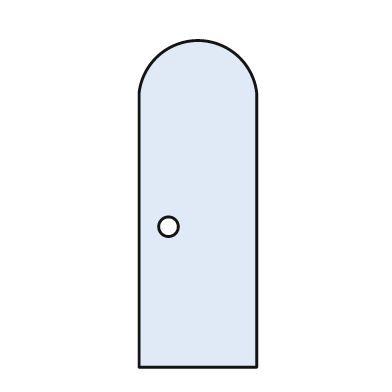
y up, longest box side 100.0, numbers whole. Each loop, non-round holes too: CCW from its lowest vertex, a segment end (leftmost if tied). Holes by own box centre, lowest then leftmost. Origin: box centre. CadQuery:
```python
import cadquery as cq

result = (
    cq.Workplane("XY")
    .moveTo(-18.0, -50.0)
    .lineTo(18.0, -50.0)
    .lineTo(18.0, 34.0)
    .threePointArc((0.0, 50.0), (-18.0, 34.0))
    .close()
    .moveTo(-9.0, -7.0)
    .circle(3.0)
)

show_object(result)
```